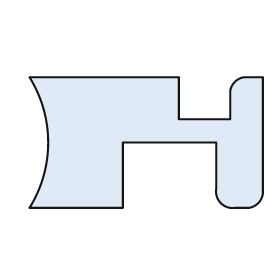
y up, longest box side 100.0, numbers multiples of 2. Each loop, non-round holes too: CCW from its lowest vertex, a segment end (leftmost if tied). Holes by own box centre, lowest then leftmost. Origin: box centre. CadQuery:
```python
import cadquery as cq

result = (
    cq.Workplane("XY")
    .moveTo(-50.0, -28.0)
    .lineTo(-10.0, -28.0)
    .lineTo(-10.0, 0.0)
    .lineTo(30.0, 0.0)
    .lineTo(30.0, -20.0)
    .threePointArc((32.0, -26.0), (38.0, -28.0))
    .lineTo(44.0, -28.0)
    .threePointArc((48.0, -26.0), (50.0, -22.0))
    .lineTo(50.0, 28.0)
    .lineTo(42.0, 28.0)
    .threePointArc((38.0, 26.0), (36.0, 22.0))
    .lineTo(36.0, 10.0)
    .lineTo(14.0, 10.0)
    .lineTo(14.0, 28.0)
    .lineTo(-50.0, 28.0)
    .threePointArc((-42.0, 0.0), (-50.0, -28.0))
    .close()
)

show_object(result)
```